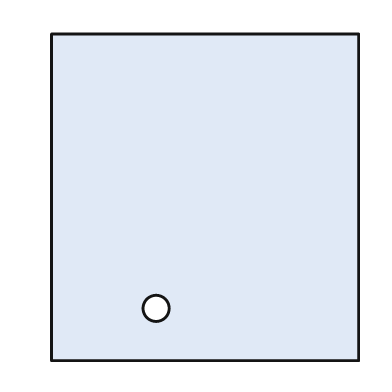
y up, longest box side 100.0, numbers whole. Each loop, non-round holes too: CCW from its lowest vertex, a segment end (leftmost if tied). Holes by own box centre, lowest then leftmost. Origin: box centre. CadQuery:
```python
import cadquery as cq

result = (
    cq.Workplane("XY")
    .moveTo(-47.0, -50.0)
    .lineTo(47.0, -50.0)
    .lineTo(47.0, 50.0)
    .lineTo(-47.0, 50.0)
    .close()
    .moveTo(-15.0, -34.0)
    .circle(4.0)
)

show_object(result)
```